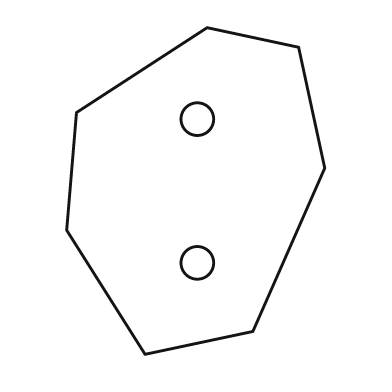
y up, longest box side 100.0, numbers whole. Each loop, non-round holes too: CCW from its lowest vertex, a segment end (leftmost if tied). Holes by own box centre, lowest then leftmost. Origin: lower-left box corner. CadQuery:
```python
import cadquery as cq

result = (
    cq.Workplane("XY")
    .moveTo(24.0, 0.0)
    .lineTo(57.0, 7.0)
    .lineTo(79.0, 57.0)
    .lineTo(71.0, 94.0)
    .lineTo(43.0, 100.0)
    .lineTo(3.0, 74.0)
    .lineTo(0.0, 38.0)
    .close()
    .moveTo(40.0, 28.0)
    .circle(5.0)
    .moveTo(40.0, 72.0)
    .circle(5.0)
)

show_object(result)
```